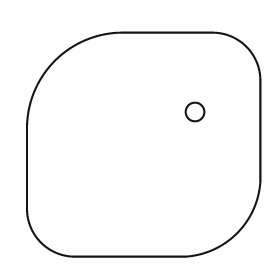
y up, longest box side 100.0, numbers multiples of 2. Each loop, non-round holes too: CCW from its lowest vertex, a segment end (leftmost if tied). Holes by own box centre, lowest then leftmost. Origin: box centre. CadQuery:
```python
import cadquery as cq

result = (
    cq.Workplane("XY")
    .moveTo(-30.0, -48.0)
    .lineTo(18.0, -48.0)
    .threePointArc((40.0, -38.0), (50.0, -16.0))
    .lineTo(50.0, 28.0)
    .threePointArc((44.0, 42.0), (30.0, 48.0))
    .lineTo(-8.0, 48.0)
    .threePointArc((-38.0, 36.0), (-50.0, 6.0))
    .lineTo(-50.0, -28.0)
    .threePointArc((-44.0, -42.0), (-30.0, -48.0))
    .close()
    .moveTo(22.0, 14.0)
    .circle(4.0)
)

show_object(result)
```